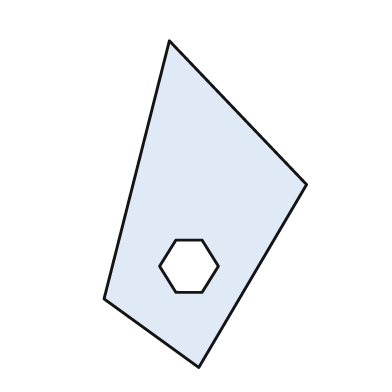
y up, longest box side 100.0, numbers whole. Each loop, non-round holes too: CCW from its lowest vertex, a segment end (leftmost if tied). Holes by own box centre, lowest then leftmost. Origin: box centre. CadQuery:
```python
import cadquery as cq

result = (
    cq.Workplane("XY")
    .moveTo(-2.0, -50.0)
    .lineTo(31.0, 6.0)
    .lineTo(-11.0, 50.0)
    .lineTo(-31.0, -29.0)
    .close()
    .moveTo(-9.0, -27.0)
    .lineTo(-1.0, -27.0)
    .lineTo(4.0, -19.0)
    .lineTo(-1.0, -11.0)
    .lineTo(-9.0, -11.0)
    .lineTo(-14.0, -19.0)
    .close()
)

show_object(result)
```